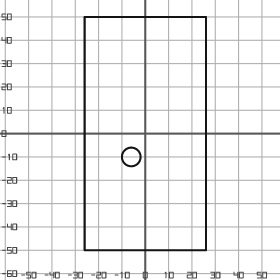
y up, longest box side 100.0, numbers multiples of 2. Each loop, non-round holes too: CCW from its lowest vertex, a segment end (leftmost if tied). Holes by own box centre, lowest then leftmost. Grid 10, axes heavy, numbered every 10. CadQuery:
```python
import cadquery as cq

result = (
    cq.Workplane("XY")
    .moveTo(-26.0, -50.0)
    .lineTo(26.0, -50.0)
    .lineTo(26.0, 50.0)
    .lineTo(-26.0, 50.0)
    .close()
    .moveTo(-6.0, -10.0)
    .circle(4.0)
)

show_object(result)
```